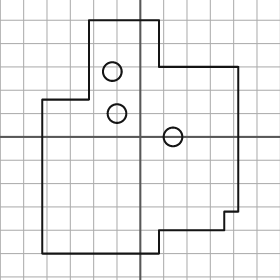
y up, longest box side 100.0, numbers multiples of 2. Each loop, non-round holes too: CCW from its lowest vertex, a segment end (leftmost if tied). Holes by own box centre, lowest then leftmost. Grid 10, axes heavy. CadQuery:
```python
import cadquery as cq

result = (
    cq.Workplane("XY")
    .moveTo(-42.0, -50.0)
    .lineTo(8.0, -50.0)
    .lineTo(8.0, -40.0)
    .lineTo(36.0, -40.0)
    .lineTo(36.0, -32.0)
    .lineTo(42.0, -32.0)
    .lineTo(42.0, 30.0)
    .lineTo(8.0, 30.0)
    .lineTo(8.0, 50.0)
    .lineTo(-22.0, 50.0)
    .lineTo(-22.0, 16.0)
    .lineTo(-42.0, 16.0)
    .close()
    .moveTo(14.0, 0.0)
    .circle(4.0)
    .moveTo(-10.0, 10.0)
    .circle(4.0)
    .moveTo(-12.0, 28.0)
    .circle(4.0)
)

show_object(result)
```